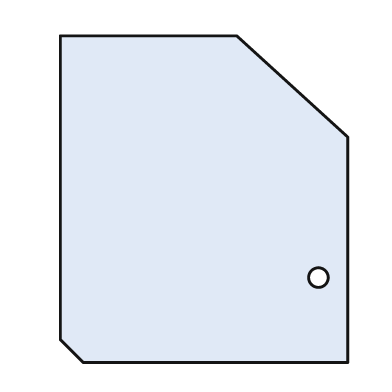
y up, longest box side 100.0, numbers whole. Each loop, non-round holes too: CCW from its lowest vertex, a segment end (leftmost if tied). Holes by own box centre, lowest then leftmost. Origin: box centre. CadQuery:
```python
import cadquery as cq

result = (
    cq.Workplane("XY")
    .moveTo(-37.0, -50.0)
    .lineTo(44.0, -50.0)
    .lineTo(44.0, 19.0)
    .lineTo(10.0, 50.0)
    .lineTo(-44.0, 50.0)
    .lineTo(-44.0, -43.0)
    .close()
    .moveTo(35.0, -24.0)
    .circle(3.0)
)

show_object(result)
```